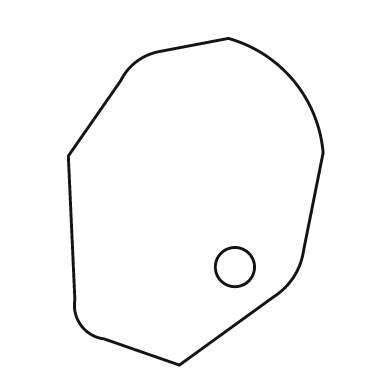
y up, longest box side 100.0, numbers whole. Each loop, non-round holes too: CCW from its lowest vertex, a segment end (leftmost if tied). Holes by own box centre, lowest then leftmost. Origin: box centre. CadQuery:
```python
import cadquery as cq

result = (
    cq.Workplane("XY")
    .moveTo(-5.0, -50.0)
    .lineTo(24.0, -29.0)
    .threePointArc((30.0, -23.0), (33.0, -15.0))
    .lineTo(39.0, 15.0)
    .threePointArc((30.0, 37.0), (10.0, 50.0))
    .lineTo(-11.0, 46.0)
    .threePointArc((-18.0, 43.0), (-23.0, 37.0))
    .lineTo(-39.0, 14.0)
    .lineTo(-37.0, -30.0)
    .threePointArc((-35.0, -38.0), (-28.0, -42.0))
    .close()
    .moveTo(12.0, -20.0)
    .circle(6.0)
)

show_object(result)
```